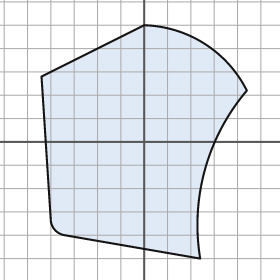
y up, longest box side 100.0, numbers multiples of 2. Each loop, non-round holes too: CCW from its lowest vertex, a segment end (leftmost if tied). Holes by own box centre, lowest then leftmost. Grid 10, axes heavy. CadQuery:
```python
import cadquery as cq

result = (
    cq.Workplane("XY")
    .moveTo(24.0, -50.0)
    .threePointArc((26.0, -12.0), (44.0, 22.0))
    .threePointArc((26.0, 42.0), (0.0, 50.0))
    .lineTo(-44.0, 28.0)
    .lineTo(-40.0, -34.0)
    .threePointArc((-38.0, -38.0), (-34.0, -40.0))
    .close()
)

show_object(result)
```